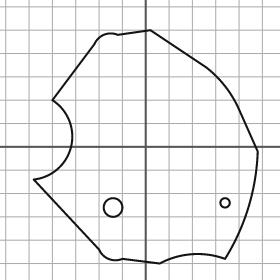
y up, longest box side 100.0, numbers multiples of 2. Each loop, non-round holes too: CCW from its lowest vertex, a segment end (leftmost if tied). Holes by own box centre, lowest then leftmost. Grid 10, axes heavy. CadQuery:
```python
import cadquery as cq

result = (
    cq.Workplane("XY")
    .moveTo(6.0, -50.0)
    .threePointArc((20.0, -46.0), (34.0, -48.0))
    .threePointArc((44.0, -26.0), (48.0, -2.0))
    .lineTo(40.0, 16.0)
    .threePointArc((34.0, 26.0), (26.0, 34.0))
    .lineTo(2.0, 50.0)
    .lineTo(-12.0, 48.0)
    .threePointArc((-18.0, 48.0), (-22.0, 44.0))
    .lineTo(-40.0, 20.0)
    .threePointArc((-32.0, 0.0), (-48.0, -14.0))
    .lineTo(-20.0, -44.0)
    .threePointArc((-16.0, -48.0), (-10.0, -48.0))
    .close()
    .moveTo(-14.0, -26.0)
    .circle(4.0)
    .moveTo(34.0, -24.0)
    .circle(2.0)
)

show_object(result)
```